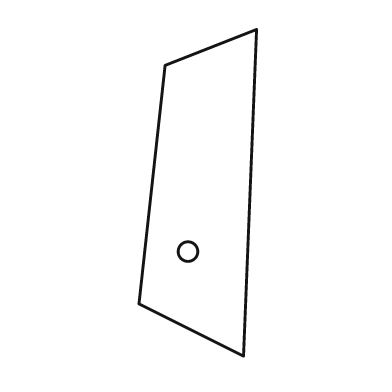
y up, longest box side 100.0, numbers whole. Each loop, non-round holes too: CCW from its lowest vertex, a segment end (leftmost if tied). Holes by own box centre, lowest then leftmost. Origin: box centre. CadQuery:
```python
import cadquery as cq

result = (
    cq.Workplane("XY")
    .moveTo(14.0, -50.0)
    .lineTo(18.0, 50.0)
    .lineTo(-10.0, 39.0)
    .lineTo(-18.0, -34.0)
    .close()
    .moveTo(-3.0, -18.0)
    .circle(3.0)
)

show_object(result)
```